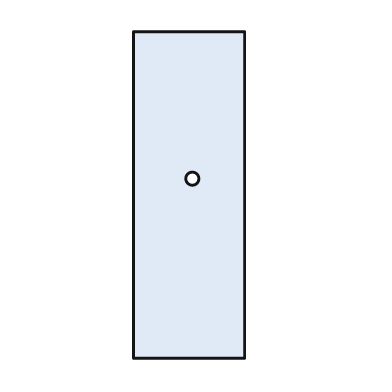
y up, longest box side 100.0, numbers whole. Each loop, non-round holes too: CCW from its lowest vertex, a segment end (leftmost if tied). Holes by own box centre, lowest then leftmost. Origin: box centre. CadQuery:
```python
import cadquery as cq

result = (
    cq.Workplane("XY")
    .moveTo(-17.0, -50.0)
    .lineTo(17.0, -50.0)
    .lineTo(17.0, 50.0)
    .lineTo(-17.0, 50.0)
    .close()
    .moveTo(1.0, 5.0)
    .circle(2.0)
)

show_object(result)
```